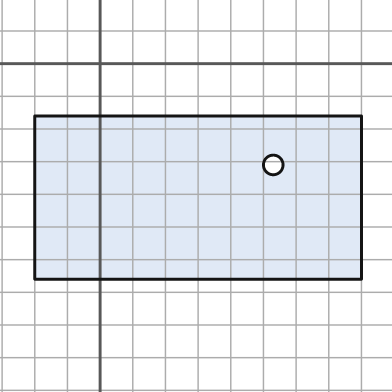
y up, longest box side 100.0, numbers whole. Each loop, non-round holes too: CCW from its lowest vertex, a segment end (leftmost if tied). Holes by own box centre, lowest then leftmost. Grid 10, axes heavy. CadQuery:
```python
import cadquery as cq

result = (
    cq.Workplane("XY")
    .moveTo(-20.0, -66.0)
    .lineTo(80.0, -66.0)
    .lineTo(80.0, -16.0)
    .lineTo(-20.0, -16.0)
    .close()
    .moveTo(53.0, -31.0)
    .circle(3.0)
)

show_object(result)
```